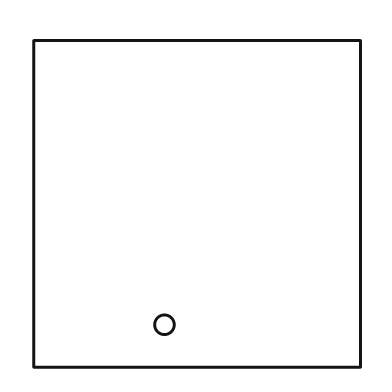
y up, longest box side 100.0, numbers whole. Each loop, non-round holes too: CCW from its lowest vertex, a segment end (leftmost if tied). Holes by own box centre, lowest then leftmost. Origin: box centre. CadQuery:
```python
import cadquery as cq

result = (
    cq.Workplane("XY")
    .moveTo(-50.0, -50.0)
    .lineTo(50.0, -50.0)
    .lineTo(50.0, 50.0)
    .lineTo(-50.0, 50.0)
    .close()
    .moveTo(-10.0, -37.0)
    .circle(3.0)
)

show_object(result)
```